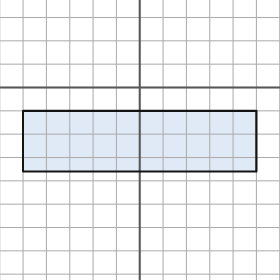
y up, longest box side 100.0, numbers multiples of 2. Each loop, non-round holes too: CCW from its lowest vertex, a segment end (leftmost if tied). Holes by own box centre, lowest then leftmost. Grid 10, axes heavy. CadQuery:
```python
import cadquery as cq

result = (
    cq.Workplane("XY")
    .moveTo(-50.0, -36.0)
    .lineTo(50.0, -36.0)
    .lineTo(50.0, -10.0)
    .lineTo(-50.0, -10.0)
    .close()
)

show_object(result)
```